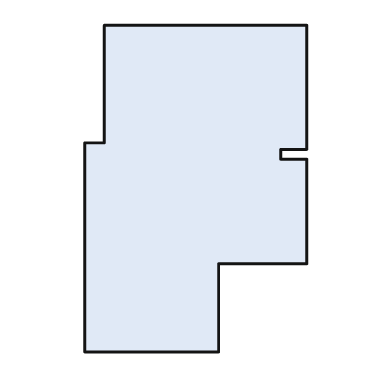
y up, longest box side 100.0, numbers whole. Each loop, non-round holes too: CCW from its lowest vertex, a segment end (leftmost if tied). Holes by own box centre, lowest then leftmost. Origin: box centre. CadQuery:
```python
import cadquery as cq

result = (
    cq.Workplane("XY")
    .moveTo(-34.0, -50.0)
    .lineTo(7.0, -50.0)
    .lineTo(7.0, -23.0)
    .lineTo(34.0, -23.0)
    .lineTo(34.0, 9.0)
    .lineTo(26.0, 9.0)
    .lineTo(26.0, 12.0)
    .lineTo(34.0, 12.0)
    .lineTo(34.0, 50.0)
    .lineTo(-28.0, 50.0)
    .lineTo(-28.0, 14.0)
    .lineTo(-34.0, 14.0)
    .close()
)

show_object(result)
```